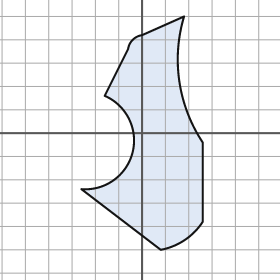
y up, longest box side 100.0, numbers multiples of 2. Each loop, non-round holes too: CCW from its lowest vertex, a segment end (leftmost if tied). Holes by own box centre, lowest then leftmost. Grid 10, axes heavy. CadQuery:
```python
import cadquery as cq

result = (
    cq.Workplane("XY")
    .moveTo(8.0, -50.0)
    .threePointArc((18.0, -46.0), (26.0, -38.0))
    .lineTo(26.0, -4.0)
    .threePointArc((16.0, 22.0), (18.0, 50.0))
    .lineTo(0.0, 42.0)
    .threePointArc((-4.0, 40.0), (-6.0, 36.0))
    .lineTo(-16.0, 16.0)
    .threePointArc((-4.0, -8.0), (-26.0, -24.0))
    .close()
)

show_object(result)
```